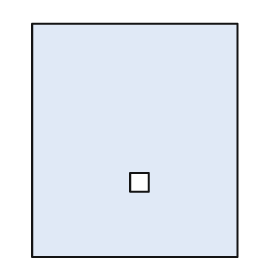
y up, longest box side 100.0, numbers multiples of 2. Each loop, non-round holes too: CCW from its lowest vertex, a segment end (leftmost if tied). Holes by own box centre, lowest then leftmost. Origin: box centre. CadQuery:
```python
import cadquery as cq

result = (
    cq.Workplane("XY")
    .moveTo(-44.0, -50.0)
    .lineTo(44.0, -50.0)
    .lineTo(44.0, 50.0)
    .lineTo(-44.0, 50.0)
    .close()
    .moveTo(-2.0, -22.0)
    .lineTo(6.0, -22.0)
    .lineTo(6.0, -14.0)
    .lineTo(-2.0, -14.0)
    .close()
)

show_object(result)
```